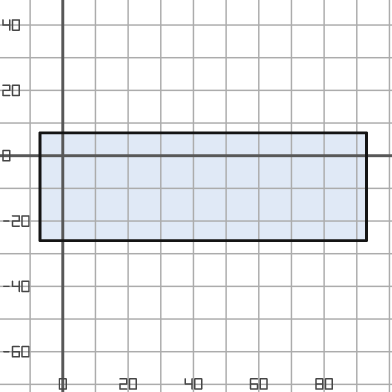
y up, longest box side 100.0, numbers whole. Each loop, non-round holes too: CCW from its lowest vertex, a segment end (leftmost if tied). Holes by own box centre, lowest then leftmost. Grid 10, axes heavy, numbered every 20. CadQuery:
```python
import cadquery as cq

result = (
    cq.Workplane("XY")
    .moveTo(-7.0, -26.0)
    .lineTo(93.0, -26.0)
    .lineTo(93.0, 7.0)
    .lineTo(-7.0, 7.0)
    .close()
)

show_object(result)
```